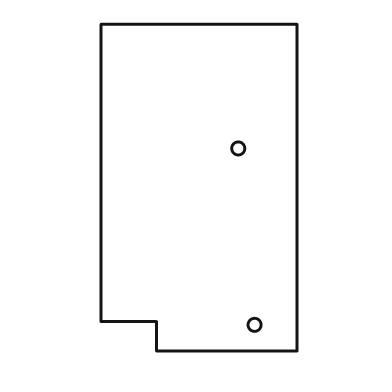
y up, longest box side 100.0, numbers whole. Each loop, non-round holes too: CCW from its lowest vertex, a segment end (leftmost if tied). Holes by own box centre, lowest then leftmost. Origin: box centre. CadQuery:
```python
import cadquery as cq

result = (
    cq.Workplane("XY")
    .moveTo(-13.0, -50.0)
    .lineTo(30.0, -50.0)
    .lineTo(30.0, 50.0)
    .lineTo(-30.0, 50.0)
    .lineTo(-30.0, -41.0)
    .lineTo(-13.0, -41.0)
    .close()
    .moveTo(17.0, -42.0)
    .circle(2.0)
    .moveTo(12.0, 12.0)
    .circle(2.0)
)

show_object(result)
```